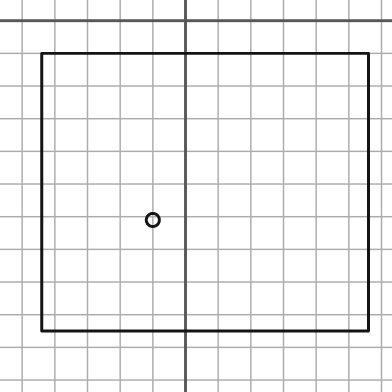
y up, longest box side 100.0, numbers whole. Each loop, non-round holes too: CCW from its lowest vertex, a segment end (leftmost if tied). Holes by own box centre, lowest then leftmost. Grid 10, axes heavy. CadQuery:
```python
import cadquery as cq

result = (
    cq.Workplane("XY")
    .moveTo(-44.0, -95.0)
    .lineTo(56.0, -95.0)
    .lineTo(56.0, -10.0)
    .lineTo(-44.0, -10.0)
    .close()
    .moveTo(-10.0, -61.0)
    .circle(2.0)
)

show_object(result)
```